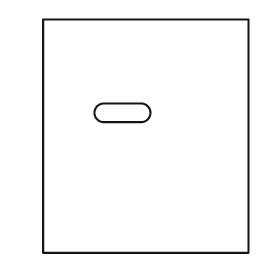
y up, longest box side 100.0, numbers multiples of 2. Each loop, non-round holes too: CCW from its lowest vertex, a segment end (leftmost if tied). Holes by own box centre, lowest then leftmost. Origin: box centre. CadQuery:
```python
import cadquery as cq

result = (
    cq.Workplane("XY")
    .moveTo(-44.0, -50.0)
    .lineTo(44.0, -50.0)
    .lineTo(44.0, 50.0)
    .lineTo(-44.0, 50.0)
    .close()
    .moveTo(-18.0, 6.0)
    .lineTo(-2.0, 6.0)
    .threePointArc((2.0, 10.0), (-2.0, 14.0))
    .lineTo(-18.0, 14.0)
    .threePointArc((-22.0, 10.0), (-18.0, 6.0))
    .close()
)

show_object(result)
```